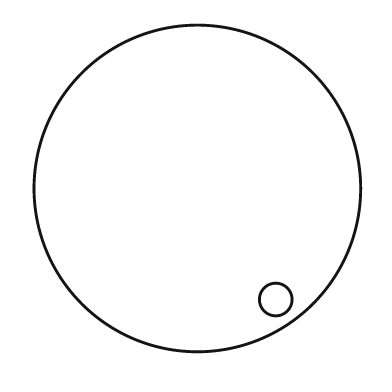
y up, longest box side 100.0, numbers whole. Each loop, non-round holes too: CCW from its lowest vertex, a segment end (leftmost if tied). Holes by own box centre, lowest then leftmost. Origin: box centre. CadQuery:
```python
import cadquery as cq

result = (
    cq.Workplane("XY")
    .moveTo(0.0, 0.0)
    .circle(50.0)
    .moveTo(24.0, -34.0)
    .circle(5.0)
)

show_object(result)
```